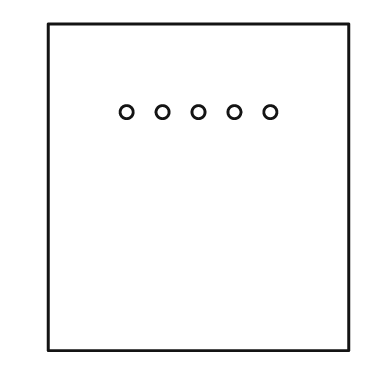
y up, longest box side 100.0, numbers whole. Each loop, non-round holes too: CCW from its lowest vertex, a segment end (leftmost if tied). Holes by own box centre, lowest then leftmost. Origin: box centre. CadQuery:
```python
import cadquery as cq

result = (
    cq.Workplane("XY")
    .moveTo(-46.0, -50.0)
    .lineTo(46.0, -50.0)
    .lineTo(46.0, 50.0)
    .lineTo(-46.0, 50.0)
    .close()
    .moveTo(-22.0, 23.0)
    .circle(2.0)
    .moveTo(-11.0, 23.0)
    .circle(2.0)
    .moveTo(0.0, 23.0)
    .circle(2.0)
    .moveTo(11.0, 23.0)
    .circle(2.0)
    .moveTo(22.0, 23.0)
    .circle(2.0)
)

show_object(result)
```